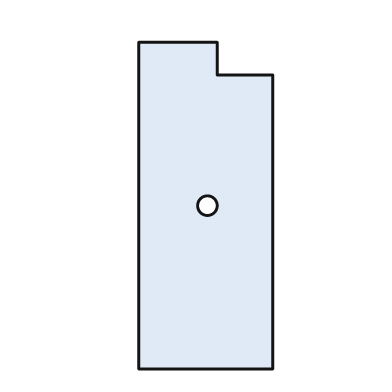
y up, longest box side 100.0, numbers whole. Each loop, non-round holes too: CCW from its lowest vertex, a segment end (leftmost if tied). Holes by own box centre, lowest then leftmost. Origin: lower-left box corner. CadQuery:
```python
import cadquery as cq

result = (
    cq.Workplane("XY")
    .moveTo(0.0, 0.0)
    .lineTo(41.0, 0.0)
    .lineTo(41.0, 90.0)
    .lineTo(24.0, 90.0)
    .lineTo(24.0, 100.0)
    .lineTo(0.0, 100.0)
    .close()
    .moveTo(21.0, 50.0)
    .circle(3.0)
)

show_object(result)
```